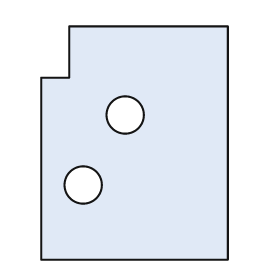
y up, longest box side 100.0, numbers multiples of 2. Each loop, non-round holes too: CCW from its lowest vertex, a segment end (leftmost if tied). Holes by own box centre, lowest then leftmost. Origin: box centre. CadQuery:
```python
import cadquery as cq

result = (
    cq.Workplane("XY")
    .moveTo(-40.0, -50.0)
    .lineTo(40.0, -50.0)
    .lineTo(40.0, 50.0)
    .lineTo(-28.0, 50.0)
    .lineTo(-28.0, 28.0)
    .lineTo(-40.0, 28.0)
    .close()
    .moveTo(-22.0, -18.0)
    .circle(8.0)
    .moveTo(-4.0, 12.0)
    .circle(8.0)
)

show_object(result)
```